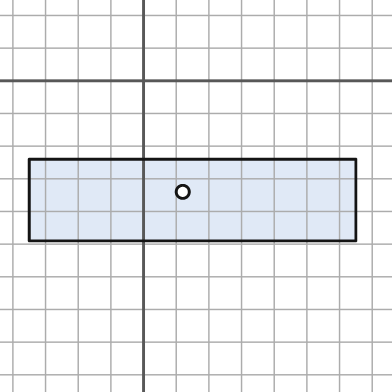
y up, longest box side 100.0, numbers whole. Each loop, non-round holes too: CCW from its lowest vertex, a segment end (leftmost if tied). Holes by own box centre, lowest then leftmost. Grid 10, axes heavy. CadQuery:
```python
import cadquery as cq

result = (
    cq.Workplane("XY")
    .moveTo(-35.0, -49.0)
    .lineTo(65.0, -49.0)
    .lineTo(65.0, -24.0)
    .lineTo(-35.0, -24.0)
    .close()
    .moveTo(12.0, -34.0)
    .circle(2.0)
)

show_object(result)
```